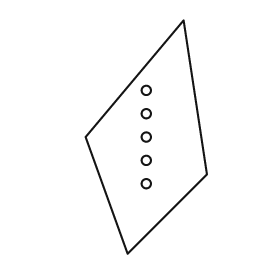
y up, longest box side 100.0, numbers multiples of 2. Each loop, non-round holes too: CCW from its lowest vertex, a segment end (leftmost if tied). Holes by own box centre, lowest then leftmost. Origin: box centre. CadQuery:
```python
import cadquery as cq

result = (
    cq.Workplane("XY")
    .moveTo(-8.0, -50.0)
    .lineTo(26.0, -16.0)
    .lineTo(16.0, 50.0)
    .lineTo(-26.0, 0.0)
    .close()
    .moveTo(0.0, -20.0)
    .circle(2.0)
    .moveTo(0.0, -10.0)
    .circle(2.0)
    .moveTo(0.0, 0.0)
    .circle(2.0)
    .moveTo(0.0, 10.0)
    .circle(2.0)
    .moveTo(0.0, 20.0)
    .circle(2.0)
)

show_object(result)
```